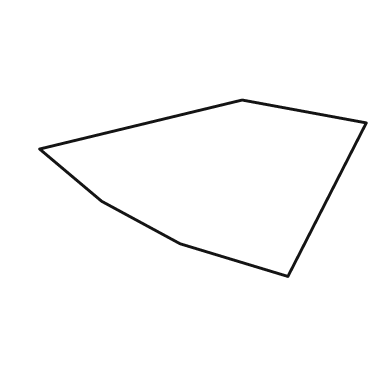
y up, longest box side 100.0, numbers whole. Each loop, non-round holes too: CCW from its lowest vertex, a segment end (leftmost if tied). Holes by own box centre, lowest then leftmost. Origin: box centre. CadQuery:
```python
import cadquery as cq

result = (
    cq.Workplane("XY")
    .moveTo(26.0, -27.0)
    .lineTo(50.0, 20.0)
    .lineTo(12.0, 27.0)
    .lineTo(-50.0, 12.0)
    .lineTo(-31.0, -4.0)
    .lineTo(-7.0, -17.0)
    .close()
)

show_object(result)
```